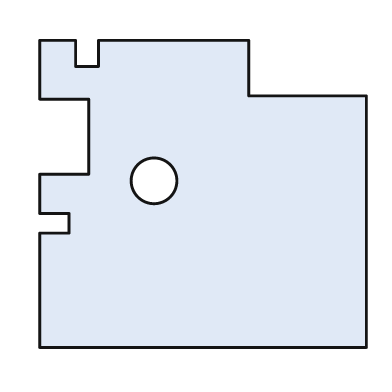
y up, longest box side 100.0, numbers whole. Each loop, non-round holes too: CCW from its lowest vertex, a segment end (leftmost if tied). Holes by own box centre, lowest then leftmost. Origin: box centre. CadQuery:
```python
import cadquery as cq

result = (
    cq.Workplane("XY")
    .moveTo(-50.0, -47.0)
    .lineTo(50.0, -47.0)
    .lineTo(50.0, 30.0)
    .lineTo(14.0, 30.0)
    .lineTo(14.0, 47.0)
    .lineTo(-32.0, 47.0)
    .lineTo(-32.0, 39.0)
    .lineTo(-39.0, 39.0)
    .lineTo(-39.0, 47.0)
    .lineTo(-50.0, 47.0)
    .lineTo(-50.0, 29.0)
    .lineTo(-35.0, 29.0)
    .lineTo(-35.0, 6.0)
    .lineTo(-50.0, 6.0)
    .lineTo(-50.0, -6.0)
    .lineTo(-41.0, -6.0)
    .lineTo(-41.0, -12.0)
    .lineTo(-50.0, -12.0)
    .close()
    .moveTo(-15.0, 4.0)
    .circle(7.0)
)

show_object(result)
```